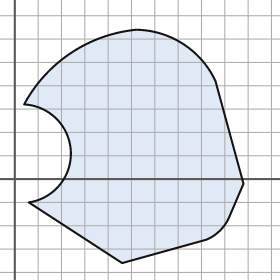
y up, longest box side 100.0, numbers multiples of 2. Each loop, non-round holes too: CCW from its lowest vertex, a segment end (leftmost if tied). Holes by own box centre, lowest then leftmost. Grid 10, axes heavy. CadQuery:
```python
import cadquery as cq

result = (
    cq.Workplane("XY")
    .moveTo(46.0, -36.0)
    .lineTo(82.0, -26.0)
    .threePointArc((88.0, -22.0), (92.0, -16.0))
    .lineTo(98.0, -2.0)
    .lineTo(86.0, 42.0)
    .threePointArc((72.0, 58.0), (52.0, 64.0))
    .threePointArc((24.0, 54.0), (4.0, 32.0))
    .threePointArc((24.0, 12.0), (6.0, -10.0))
    .close()
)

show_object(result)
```